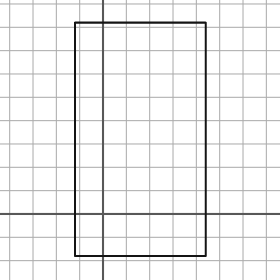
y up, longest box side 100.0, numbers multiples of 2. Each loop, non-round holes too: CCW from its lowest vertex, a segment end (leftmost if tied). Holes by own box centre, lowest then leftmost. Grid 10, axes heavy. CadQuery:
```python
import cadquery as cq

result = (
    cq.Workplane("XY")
    .moveTo(-12.0, -18.0)
    .lineTo(44.0, -18.0)
    .lineTo(44.0, 82.0)
    .lineTo(-12.0, 82.0)
    .close()
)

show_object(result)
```